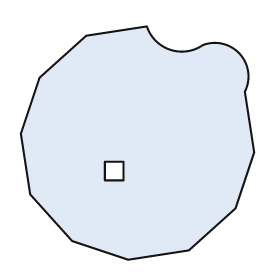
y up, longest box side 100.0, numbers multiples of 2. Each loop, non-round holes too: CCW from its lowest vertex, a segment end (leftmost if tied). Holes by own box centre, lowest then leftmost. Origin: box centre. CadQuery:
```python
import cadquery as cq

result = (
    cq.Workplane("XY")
    .moveTo(-4.0, -50.0)
    .lineTo(22.0, -46.0)
    .lineTo(42.0, -28.0)
    .lineTo(50.0, -4.0)
    .lineTo(46.0, 22.0)
    .threePointArc((44.0, 38.0), (28.0, 42.0))
    .threePointArc((14.0, 40.0), (4.0, 50.0))
    .lineTo(-22.0, 46.0)
    .lineTo(-42.0, 28.0)
    .lineTo(-50.0, 4.0)
    .lineTo(-46.0, -22.0)
    .lineTo(-28.0, -42.0)
    .close()
    .moveTo(-14.0, -16.0)
    .lineTo(-6.0, -16.0)
    .lineTo(-6.0, -8.0)
    .lineTo(-14.0, -8.0)
    .close()
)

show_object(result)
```